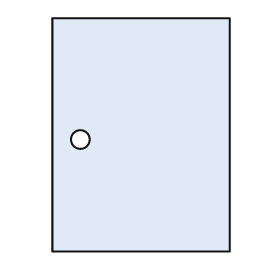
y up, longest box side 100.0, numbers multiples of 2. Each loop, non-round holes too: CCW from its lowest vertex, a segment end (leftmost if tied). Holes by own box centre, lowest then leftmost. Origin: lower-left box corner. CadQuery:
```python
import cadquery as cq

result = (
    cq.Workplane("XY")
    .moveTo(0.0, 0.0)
    .lineTo(76.0, 0.0)
    .lineTo(76.0, 100.0)
    .lineTo(0.0, 100.0)
    .close()
    .moveTo(12.0, 48.0)
    .circle(4.0)
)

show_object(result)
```